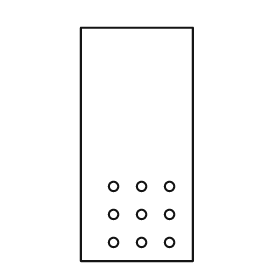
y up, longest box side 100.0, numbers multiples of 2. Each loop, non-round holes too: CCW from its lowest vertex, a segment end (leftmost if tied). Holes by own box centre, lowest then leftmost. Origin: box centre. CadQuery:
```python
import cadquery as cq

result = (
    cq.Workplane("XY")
    .moveTo(-24.0, -50.0)
    .lineTo(24.0, -50.0)
    .lineTo(24.0, 50.0)
    .lineTo(-24.0, 50.0)
    .close()
    .moveTo(-10.0, -42.0)
    .circle(2.0)
    .moveTo(2.0, -42.0)
    .circle(2.0)
    .moveTo(14.0, -42.0)
    .circle(2.0)
    .moveTo(-10.0, -30.0)
    .circle(2.0)
    .moveTo(2.0, -30.0)
    .circle(2.0)
    .moveTo(14.0, -30.0)
    .circle(2.0)
    .moveTo(-10.0, -18.0)
    .circle(2.0)
    .moveTo(2.0, -18.0)
    .circle(2.0)
    .moveTo(14.0, -18.0)
    .circle(2.0)
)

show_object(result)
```